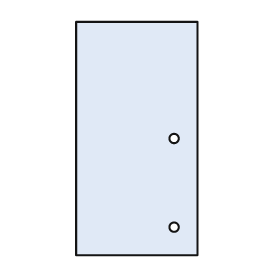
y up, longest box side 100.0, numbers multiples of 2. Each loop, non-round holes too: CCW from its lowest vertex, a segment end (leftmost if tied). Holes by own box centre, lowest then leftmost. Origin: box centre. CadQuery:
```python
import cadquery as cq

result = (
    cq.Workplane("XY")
    .moveTo(-26.0, -50.0)
    .lineTo(26.0, -50.0)
    .lineTo(26.0, 50.0)
    .lineTo(-26.0, 50.0)
    .close()
    .moveTo(16.0, -38.0)
    .circle(2.0)
    .moveTo(16.0, 0.0)
    .circle(2.0)
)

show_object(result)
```